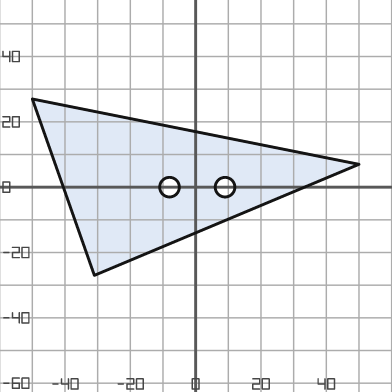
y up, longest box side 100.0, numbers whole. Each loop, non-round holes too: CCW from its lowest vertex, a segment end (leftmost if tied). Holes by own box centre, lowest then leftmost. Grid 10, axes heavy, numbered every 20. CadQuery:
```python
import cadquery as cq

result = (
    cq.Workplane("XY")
    .moveTo(-31.0, -27.0)
    .lineTo(50.0, 7.0)
    .lineTo(-50.0, 27.0)
    .close()
    .moveTo(-8.0, 0.0)
    .circle(3.0)
    .moveTo(9.0, 0.0)
    .circle(3.0)
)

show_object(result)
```